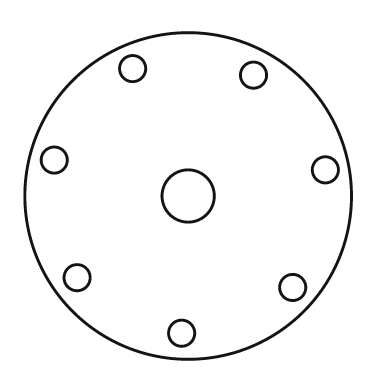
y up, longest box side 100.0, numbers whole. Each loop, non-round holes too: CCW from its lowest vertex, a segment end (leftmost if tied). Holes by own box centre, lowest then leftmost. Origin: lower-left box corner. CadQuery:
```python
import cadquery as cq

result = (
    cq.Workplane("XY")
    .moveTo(50.0, 50.0)
    .circle(50.0)
    .moveTo(48.0, 8.0)
    .circle(4.0)
    .moveTo(82.0, 22.0)
    .circle(4.0)
    .moveTo(16.0, 25.0)
    .circle(4.0)
    .moveTo(50.0, 50.0)
    .circle(8.0)
    .moveTo(92.0, 58.0)
    .circle(4.0)
    .moveTo(9.0, 61.0)
    .circle(4.0)
    .moveTo(70.0, 87.0)
    .circle(4.0)
    .moveTo(33.0, 89.0)
    .circle(4.0)
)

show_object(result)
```